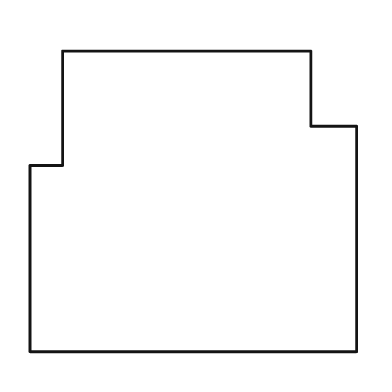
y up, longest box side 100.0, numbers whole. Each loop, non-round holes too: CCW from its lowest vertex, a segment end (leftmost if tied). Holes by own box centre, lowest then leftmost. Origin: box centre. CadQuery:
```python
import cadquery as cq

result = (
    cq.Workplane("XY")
    .moveTo(-50.0, -46.0)
    .lineTo(50.0, -46.0)
    .lineTo(50.0, 23.0)
    .lineTo(36.0, 23.0)
    .lineTo(36.0, 46.0)
    .lineTo(-40.0, 46.0)
    .lineTo(-40.0, 11.0)
    .lineTo(-50.0, 11.0)
    .close()
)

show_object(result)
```